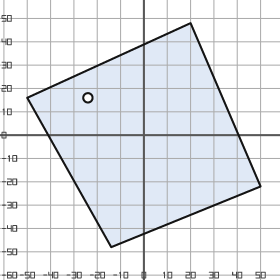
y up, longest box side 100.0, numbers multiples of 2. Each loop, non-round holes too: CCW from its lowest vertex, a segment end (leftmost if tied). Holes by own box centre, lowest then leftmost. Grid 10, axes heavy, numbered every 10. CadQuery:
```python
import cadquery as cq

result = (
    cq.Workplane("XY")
    .moveTo(-14.0, -48.0)
    .lineTo(50.0, -22.0)
    .lineTo(20.0, 48.0)
    .lineTo(-50.0, 16.0)
    .close()
    .moveTo(-24.0, 16.0)
    .circle(2.0)
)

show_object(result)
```